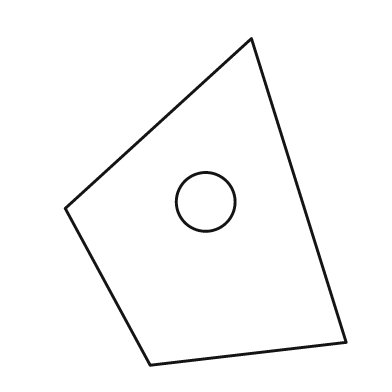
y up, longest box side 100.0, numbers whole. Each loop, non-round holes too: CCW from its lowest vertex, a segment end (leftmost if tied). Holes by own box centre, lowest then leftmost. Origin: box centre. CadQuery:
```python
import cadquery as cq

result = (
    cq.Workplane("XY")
    .moveTo(-17.0, -50.0)
    .lineTo(43.0, -43.0)
    .lineTo(14.0, 50.0)
    .lineTo(-43.0, -2.0)
    .close()
    .moveTo(0.0, 0.0)
    .circle(9.0)
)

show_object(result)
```